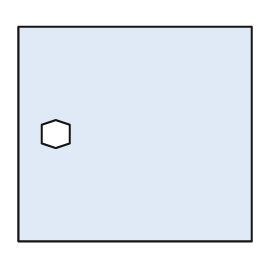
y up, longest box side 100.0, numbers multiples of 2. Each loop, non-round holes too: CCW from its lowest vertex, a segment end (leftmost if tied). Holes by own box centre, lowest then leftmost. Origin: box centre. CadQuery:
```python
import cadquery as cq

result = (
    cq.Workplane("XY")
    .moveTo(-50.0, -46.0)
    .lineTo(50.0, -46.0)
    .lineTo(50.0, 46.0)
    .lineTo(-50.0, 46.0)
    .close()
    .moveTo(-34.0, -6.0)
    .lineTo(-28.0, -4.0)
    .lineTo(-28.0, 4.0)
    .lineTo(-34.0, 6.0)
    .lineTo(-40.0, 4.0)
    .lineTo(-40.0, -4.0)
    .close()
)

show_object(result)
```